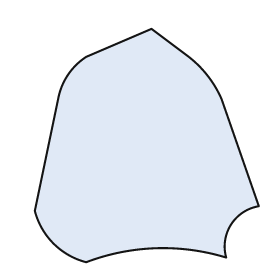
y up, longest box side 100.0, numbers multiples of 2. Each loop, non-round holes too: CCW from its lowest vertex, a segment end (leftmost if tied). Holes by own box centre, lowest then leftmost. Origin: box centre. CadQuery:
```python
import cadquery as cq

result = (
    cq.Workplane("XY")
    .moveTo(-26.0, -50.0)
    .threePointArc((4.0, -44.0), (34.0, -48.0))
    .threePointArc((36.0, -34.0), (48.0, -26.0))
    .lineTo(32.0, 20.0)
    .threePointArc((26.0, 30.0), (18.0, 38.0))
    .lineTo(2.0, 50.0)
    .lineTo(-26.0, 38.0)
    .threePointArc((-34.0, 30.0), (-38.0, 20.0))
    .lineTo(-48.0, -28.0)
    .threePointArc((-40.0, -42.0), (-26.0, -50.0))
    .close()
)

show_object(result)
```